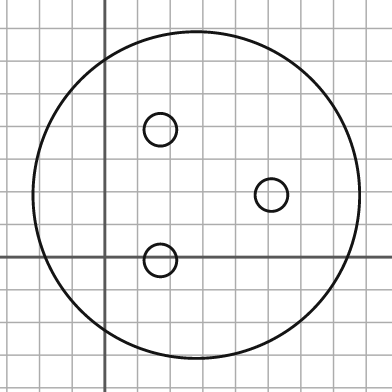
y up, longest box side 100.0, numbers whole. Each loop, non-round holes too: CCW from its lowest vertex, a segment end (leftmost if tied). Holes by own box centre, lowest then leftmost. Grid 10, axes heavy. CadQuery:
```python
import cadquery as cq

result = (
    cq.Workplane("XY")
    .moveTo(28.0, 19.0)
    .circle(50.0)
    .moveTo(17.0, -1.0)
    .circle(5.0)
    .moveTo(51.0, 19.0)
    .circle(5.0)
    .moveTo(17.0, 39.0)
    .circle(5.0)
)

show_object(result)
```